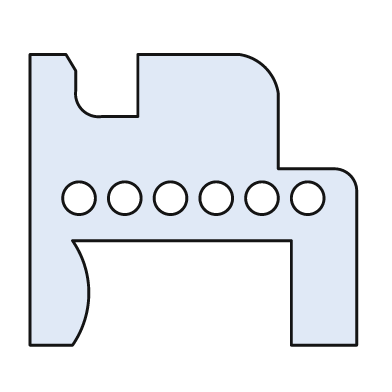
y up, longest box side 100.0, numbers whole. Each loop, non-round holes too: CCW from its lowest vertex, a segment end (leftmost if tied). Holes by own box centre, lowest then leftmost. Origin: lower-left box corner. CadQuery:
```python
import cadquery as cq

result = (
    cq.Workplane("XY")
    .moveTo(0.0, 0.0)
    .lineTo(13.0, 0.0)
    .threePointArc((18.0, 16.0), (13.0, 32.0))
    .lineTo(80.0, 32.0)
    .lineTo(80.0, 0.0)
    .lineTo(100.0, 0.0)
    .lineTo(100.0, 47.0)
    .threePointArc((98.0, 52.0), (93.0, 54.0))
    .lineTo(76.0, 54.0)
    .lineTo(76.0, 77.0)
    .threePointArc((72.0, 85.0), (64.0, 89.0))
    .lineTo(33.0, 89.0)
    .lineTo(33.0, 70.0)
    .lineTo(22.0, 70.0)
    .threePointArc((16.0, 72.0), (14.0, 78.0))
    .lineTo(14.0, 84.0)
    .lineTo(11.0, 89.0)
    .lineTo(0.0, 89.0)
    .close()
    .moveTo(15.0, 45.0)
    .circle(5.0)
    .moveTo(29.0, 45.0)
    .circle(5.0)
    .moveTo(43.0, 45.0)
    .circle(5.0)
    .moveTo(57.0, 45.0)
    .circle(5.0)
    .moveTo(71.0, 45.0)
    .circle(5.0)
    .moveTo(85.0, 45.0)
    .circle(5.0)
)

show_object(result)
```